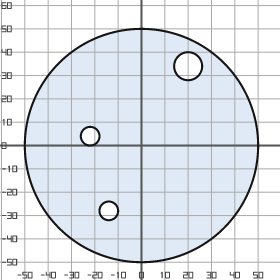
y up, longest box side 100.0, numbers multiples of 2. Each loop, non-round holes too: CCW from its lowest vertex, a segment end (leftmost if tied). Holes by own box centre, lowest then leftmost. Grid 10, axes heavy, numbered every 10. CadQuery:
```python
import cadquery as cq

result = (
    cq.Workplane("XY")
    .moveTo(0.0, 0.0)
    .circle(50.0)
    .moveTo(-14.0, -28.0)
    .circle(4.0)
    .moveTo(-22.0, 4.0)
    .circle(4.0)
    .moveTo(20.0, 34.0)
    .circle(6.0)
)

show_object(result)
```